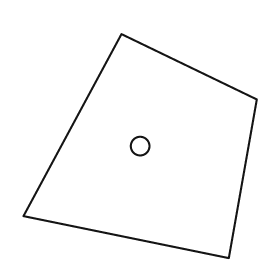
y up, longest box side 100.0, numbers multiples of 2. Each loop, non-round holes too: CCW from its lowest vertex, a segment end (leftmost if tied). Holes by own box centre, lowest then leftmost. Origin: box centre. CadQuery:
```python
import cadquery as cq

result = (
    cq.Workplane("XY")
    .moveTo(38.0, -48.0)
    .lineTo(50.0, 20.0)
    .lineTo(-8.0, 48.0)
    .lineTo(-50.0, -30.0)
    .close()
    .moveTo(0.0, 0.0)
    .circle(4.0)
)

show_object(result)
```